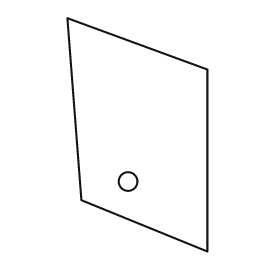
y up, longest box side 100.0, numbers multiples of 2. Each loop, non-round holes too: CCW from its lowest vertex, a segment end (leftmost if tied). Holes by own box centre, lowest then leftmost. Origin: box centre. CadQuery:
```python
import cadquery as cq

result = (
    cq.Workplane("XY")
    .moveTo(30.0, -50.0)
    .lineTo(30.0, 28.0)
    .lineTo(-30.0, 50.0)
    .lineTo(-24.0, -28.0)
    .close()
    .moveTo(-4.0, -20.0)
    .circle(4.0)
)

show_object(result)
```